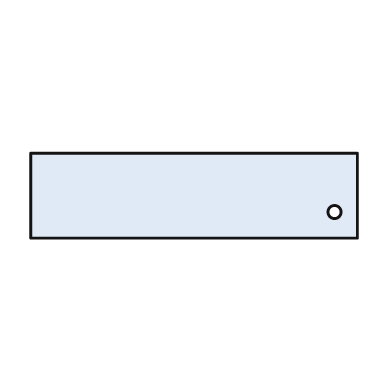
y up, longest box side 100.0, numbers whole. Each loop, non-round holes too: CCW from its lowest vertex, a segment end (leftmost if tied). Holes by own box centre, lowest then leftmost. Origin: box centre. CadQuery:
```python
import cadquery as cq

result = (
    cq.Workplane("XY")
    .moveTo(-50.0, -13.0)
    .lineTo(50.0, -13.0)
    .lineTo(50.0, 13.0)
    .lineTo(-50.0, 13.0)
    .close()
    .moveTo(43.0, -5.0)
    .circle(2.0)
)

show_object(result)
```